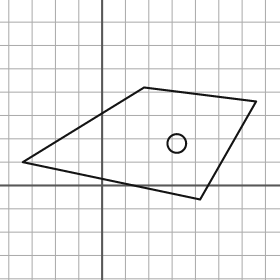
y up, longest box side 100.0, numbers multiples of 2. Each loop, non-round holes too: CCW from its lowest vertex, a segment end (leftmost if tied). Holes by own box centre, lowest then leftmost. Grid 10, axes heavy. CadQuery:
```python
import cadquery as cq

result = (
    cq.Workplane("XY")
    .moveTo(42.0, -6.0)
    .lineTo(66.0, 36.0)
    .lineTo(18.0, 42.0)
    .lineTo(-34.0, 10.0)
    .close()
    .moveTo(32.0, 18.0)
    .circle(4.0)
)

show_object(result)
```